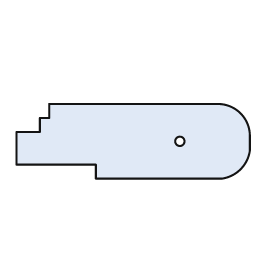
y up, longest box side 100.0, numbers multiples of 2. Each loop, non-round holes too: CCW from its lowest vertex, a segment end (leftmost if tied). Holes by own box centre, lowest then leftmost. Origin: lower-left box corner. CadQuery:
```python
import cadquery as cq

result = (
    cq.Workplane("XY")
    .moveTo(34.0, 0.0)
    .lineTo(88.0, 0.0)
    .threePointArc((96.0, 4.0), (100.0, 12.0))
    .lineTo(100.0, 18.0)
    .threePointArc((96.0, 28.0), (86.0, 32.0))
    .lineTo(14.0, 32.0)
    .lineTo(14.0, 26.0)
    .lineTo(10.0, 26.0)
    .lineTo(10.0, 20.0)
    .lineTo(0.0, 20.0)
    .lineTo(0.0, 6.0)
    .lineTo(34.0, 6.0)
    .close()
    .moveTo(70.0, 16.0)
    .circle(2.0)
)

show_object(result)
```